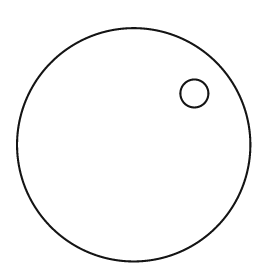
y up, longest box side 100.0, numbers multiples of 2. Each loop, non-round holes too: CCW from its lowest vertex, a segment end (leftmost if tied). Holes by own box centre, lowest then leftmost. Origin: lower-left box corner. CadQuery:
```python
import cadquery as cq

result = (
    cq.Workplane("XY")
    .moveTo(50.0, 50.0)
    .circle(50.0)
    .moveTo(76.0, 72.0)
    .circle(6.0)
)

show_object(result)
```